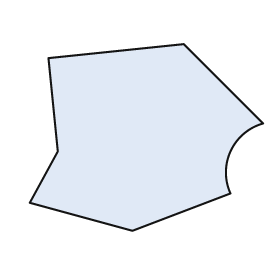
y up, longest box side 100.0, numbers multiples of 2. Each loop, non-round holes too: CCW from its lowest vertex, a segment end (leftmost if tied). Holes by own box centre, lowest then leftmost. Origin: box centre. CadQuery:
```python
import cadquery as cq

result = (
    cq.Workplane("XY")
    .moveTo(-6.0, -40.0)
    .lineTo(36.0, -24.0)
    .threePointArc((36.0, -6.0), (50.0, 6.0))
    .lineTo(16.0, 40.0)
    .lineTo(-42.0, 34.0)
    .lineTo(-38.0, -6.0)
    .lineTo(-50.0, -28.0)
    .close()
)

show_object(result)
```